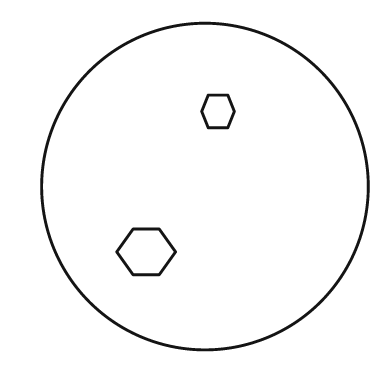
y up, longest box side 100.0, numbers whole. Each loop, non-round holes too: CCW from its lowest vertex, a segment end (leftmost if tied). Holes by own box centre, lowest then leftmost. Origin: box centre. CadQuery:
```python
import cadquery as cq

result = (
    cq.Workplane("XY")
    .moveTo(0.0, 0.0)
    .circle(50.0)
    .moveTo(-22.0, -27.0)
    .lineTo(-14.0, -27.0)
    .lineTo(-9.0, -20.0)
    .lineTo(-14.0, -13.0)
    .lineTo(-22.0, -13.0)
    .lineTo(-27.0, -20.0)
    .close()
    .moveTo(1.0, 18.0)
    .lineTo(7.0, 18.0)
    .lineTo(9.0, 23.0)
    .lineTo(7.0, 28.0)
    .lineTo(1.0, 28.0)
    .lineTo(-1.0, 23.0)
    .close()
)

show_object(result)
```